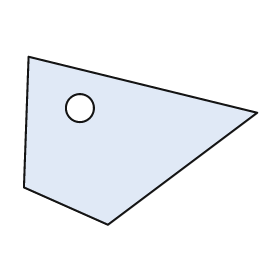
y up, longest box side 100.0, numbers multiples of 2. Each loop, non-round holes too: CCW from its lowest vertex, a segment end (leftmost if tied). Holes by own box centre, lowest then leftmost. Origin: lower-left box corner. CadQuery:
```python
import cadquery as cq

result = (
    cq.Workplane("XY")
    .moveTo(36.0, 0.0)
    .lineTo(100.0, 48.0)
    .lineTo(2.0, 72.0)
    .lineTo(0.0, 16.0)
    .close()
    .moveTo(24.0, 50.0)
    .circle(6.0)
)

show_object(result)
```